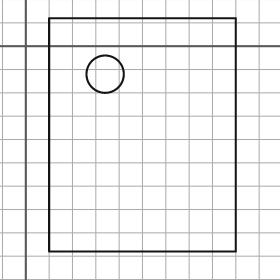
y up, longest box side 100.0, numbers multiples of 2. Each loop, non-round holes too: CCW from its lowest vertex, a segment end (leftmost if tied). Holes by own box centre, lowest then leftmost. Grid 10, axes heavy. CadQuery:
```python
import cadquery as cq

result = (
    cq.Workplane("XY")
    .moveTo(10.0, -88.0)
    .lineTo(90.0, -88.0)
    .lineTo(90.0, 12.0)
    .lineTo(10.0, 12.0)
    .close()
    .moveTo(34.0, -12.0)
    .circle(8.0)
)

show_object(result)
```